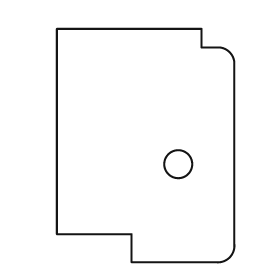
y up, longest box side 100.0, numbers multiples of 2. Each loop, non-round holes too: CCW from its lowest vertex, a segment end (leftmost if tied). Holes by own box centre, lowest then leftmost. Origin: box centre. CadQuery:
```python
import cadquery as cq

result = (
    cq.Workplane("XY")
    .moveTo(-6.0, -50.0)
    .lineTo(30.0, -50.0)
    .threePointArc((36.0, -48.0), (38.0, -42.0))
    .lineTo(38.0, 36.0)
    .threePointArc((36.0, 40.0), (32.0, 42.0))
    .lineTo(24.0, 42.0)
    .lineTo(24.0, 50.0)
    .lineTo(-38.0, 50.0)
    .lineTo(-38.0, -38.0)
    .lineTo(-6.0, -38.0)
    .close()
    .moveTo(14.0, -8.0)
    .circle(6.0)
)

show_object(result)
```